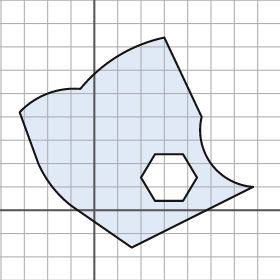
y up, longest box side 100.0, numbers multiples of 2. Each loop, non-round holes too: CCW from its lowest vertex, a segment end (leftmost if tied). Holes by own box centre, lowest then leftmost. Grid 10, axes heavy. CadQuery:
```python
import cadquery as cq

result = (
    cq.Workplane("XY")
    .moveTo(16.0, -16.0)
    .lineTo(68.0, 10.0)
    .threePointArc((50.0, 20.0), (46.0, 40.0))
    .lineTo(30.0, 74.0)
    .threePointArc((10.0, 66.0), (-6.0, 52.0))
    .threePointArc((-20.0, 50.0), (-32.0, 42.0))
    .lineTo(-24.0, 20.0)
    .threePointArc((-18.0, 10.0), (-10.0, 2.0))
    .close()
    .moveTo(26.0, 4.0)
    .lineTo(38.0, 4.0)
    .lineTo(44.0, 14.0)
    .lineTo(38.0, 24.0)
    .lineTo(26.0, 24.0)
    .lineTo(20.0, 14.0)
    .close()
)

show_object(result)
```